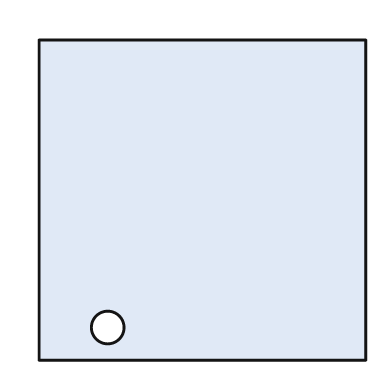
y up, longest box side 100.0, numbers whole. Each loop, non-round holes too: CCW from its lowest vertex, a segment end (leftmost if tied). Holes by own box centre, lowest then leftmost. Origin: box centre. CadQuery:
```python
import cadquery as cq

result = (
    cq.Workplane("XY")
    .moveTo(-50.0, -49.0)
    .lineTo(50.0, -49.0)
    .lineTo(50.0, 49.0)
    .lineTo(-50.0, 49.0)
    .close()
    .moveTo(-29.0, -39.0)
    .circle(5.0)
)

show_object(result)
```